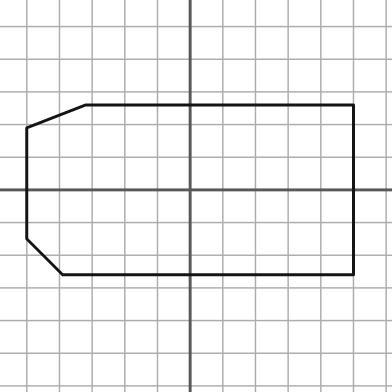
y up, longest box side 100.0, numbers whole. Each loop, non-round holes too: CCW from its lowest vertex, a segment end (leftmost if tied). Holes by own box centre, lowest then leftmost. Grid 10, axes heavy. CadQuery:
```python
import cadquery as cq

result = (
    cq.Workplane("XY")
    .moveTo(-39.0, -26.0)
    .lineTo(50.0, -26.0)
    .lineTo(50.0, 26.0)
    .lineTo(-32.0, 26.0)
    .lineTo(-50.0, 19.0)
    .lineTo(-50.0, -15.0)
    .close()
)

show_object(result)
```